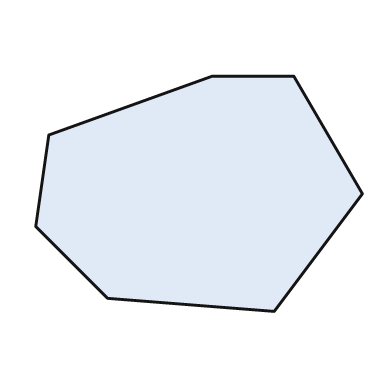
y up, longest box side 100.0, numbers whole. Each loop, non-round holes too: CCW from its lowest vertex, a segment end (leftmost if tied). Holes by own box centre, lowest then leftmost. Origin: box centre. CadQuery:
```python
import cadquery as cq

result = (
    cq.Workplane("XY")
    .moveTo(23.0, -36.0)
    .lineTo(50.0, 0.0)
    .lineTo(29.0, 36.0)
    .lineTo(4.0, 36.0)
    .lineTo(-46.0, 18.0)
    .lineTo(-50.0, -10.0)
    .lineTo(-28.0, -32.0)
    .close()
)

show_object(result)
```